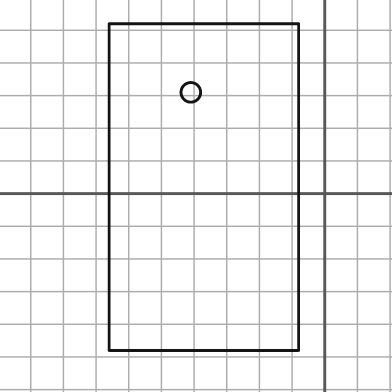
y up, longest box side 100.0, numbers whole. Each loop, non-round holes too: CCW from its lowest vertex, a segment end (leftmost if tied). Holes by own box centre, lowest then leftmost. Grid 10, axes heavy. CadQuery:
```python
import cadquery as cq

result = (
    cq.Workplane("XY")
    .moveTo(-66.0, -48.0)
    .lineTo(-8.0, -48.0)
    .lineTo(-8.0, 52.0)
    .lineTo(-66.0, 52.0)
    .close()
    .moveTo(-41.0, 31.0)
    .circle(3.0)
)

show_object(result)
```